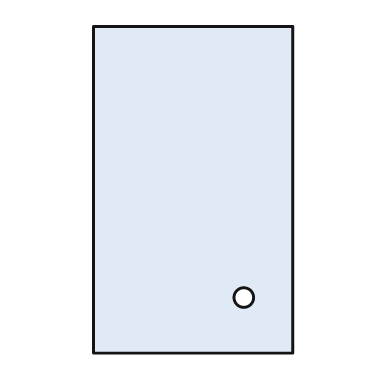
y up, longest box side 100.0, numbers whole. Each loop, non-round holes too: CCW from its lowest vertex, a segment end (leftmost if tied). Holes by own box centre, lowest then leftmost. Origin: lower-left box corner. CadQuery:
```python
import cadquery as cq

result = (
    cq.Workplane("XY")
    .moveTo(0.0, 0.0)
    .lineTo(61.0, 0.0)
    .lineTo(61.0, 100.0)
    .lineTo(0.0, 100.0)
    .close()
    .moveTo(46.0, 17.0)
    .circle(3.0)
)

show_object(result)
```